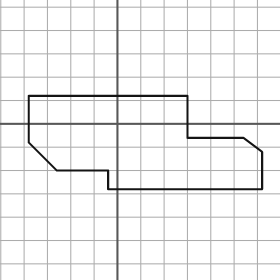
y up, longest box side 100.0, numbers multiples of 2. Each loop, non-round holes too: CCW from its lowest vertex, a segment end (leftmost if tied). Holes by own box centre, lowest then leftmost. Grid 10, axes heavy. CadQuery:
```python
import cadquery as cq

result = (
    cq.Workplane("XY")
    .moveTo(-4.0, -28.0)
    .lineTo(62.0, -28.0)
    .lineTo(62.0, -12.0)
    .lineTo(54.0, -6.0)
    .lineTo(30.0, -6.0)
    .lineTo(30.0, 12.0)
    .lineTo(-38.0, 12.0)
    .lineTo(-38.0, -8.0)
    .lineTo(-26.0, -20.0)
    .lineTo(-4.0, -20.0)
    .close()
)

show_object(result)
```